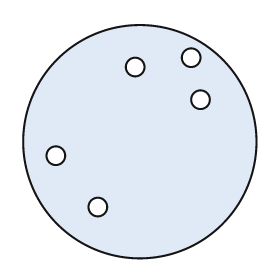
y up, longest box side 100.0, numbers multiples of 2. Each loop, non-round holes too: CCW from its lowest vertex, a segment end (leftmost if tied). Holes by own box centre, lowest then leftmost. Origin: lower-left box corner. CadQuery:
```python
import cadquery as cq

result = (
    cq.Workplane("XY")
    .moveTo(50.0, 50.0)
    .circle(50.0)
    .moveTo(32.0, 22.0)
    .circle(4.0)
    .moveTo(14.0, 44.0)
    .circle(4.0)
    .moveTo(76.0, 68.0)
    .circle(4.0)
    .moveTo(48.0, 82.0)
    .circle(4.0)
    .moveTo(72.0, 86.0)
    .circle(4.0)
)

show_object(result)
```